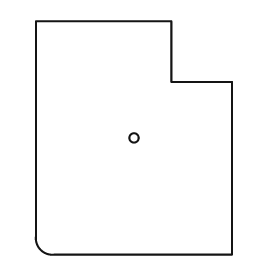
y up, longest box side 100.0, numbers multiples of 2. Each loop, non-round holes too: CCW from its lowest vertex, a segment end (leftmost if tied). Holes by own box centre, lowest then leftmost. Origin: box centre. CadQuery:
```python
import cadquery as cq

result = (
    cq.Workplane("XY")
    .moveTo(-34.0, -50.0)
    .lineTo(42.0, -50.0)
    .lineTo(42.0, 24.0)
    .lineTo(16.0, 24.0)
    .lineTo(16.0, 50.0)
    .lineTo(-42.0, 50.0)
    .lineTo(-42.0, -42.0)
    .threePointArc((-40.0, -48.0), (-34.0, -50.0))
    .close()
    .moveTo(0.0, 0.0)
    .circle(2.0)
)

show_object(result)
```